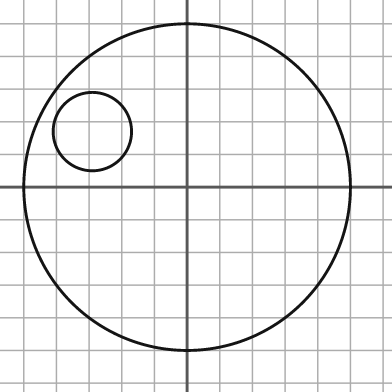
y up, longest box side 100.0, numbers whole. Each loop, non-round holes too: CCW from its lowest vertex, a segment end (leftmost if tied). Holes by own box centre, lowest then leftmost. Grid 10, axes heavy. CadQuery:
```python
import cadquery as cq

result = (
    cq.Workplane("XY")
    .moveTo(0.0, 0.0)
    .circle(50.0)
    .moveTo(-29.0, 17.0)
    .circle(12.0)
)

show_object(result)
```